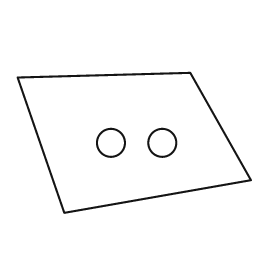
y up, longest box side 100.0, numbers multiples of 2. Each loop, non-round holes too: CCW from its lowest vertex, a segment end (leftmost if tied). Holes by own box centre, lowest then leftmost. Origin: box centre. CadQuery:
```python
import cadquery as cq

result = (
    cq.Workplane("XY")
    .moveTo(-30.0, -30.0)
    .lineTo(50.0, -16.0)
    .lineTo(24.0, 30.0)
    .lineTo(-50.0, 28.0)
    .close()
    .moveTo(-10.0, 0.0)
    .circle(6.0)
    .moveTo(12.0, 0.0)
    .circle(6.0)
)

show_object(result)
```